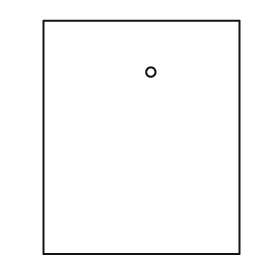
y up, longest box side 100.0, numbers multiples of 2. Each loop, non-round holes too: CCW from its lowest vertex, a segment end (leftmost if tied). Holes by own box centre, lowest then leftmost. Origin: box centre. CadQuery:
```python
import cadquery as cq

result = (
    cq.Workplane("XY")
    .moveTo(-42.0, -50.0)
    .lineTo(42.0, -50.0)
    .lineTo(42.0, 50.0)
    .lineTo(-42.0, 50.0)
    .close()
    .moveTo(4.0, 28.0)
    .circle(2.0)
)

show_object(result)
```